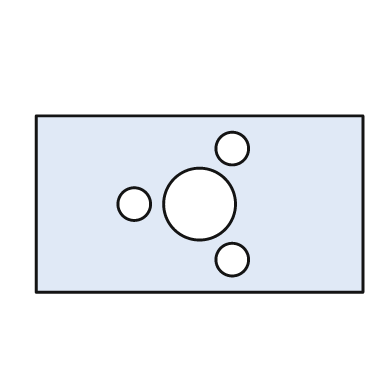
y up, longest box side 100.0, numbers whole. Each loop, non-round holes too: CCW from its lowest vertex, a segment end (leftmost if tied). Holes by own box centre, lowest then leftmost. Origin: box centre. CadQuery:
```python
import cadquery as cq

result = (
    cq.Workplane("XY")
    .moveTo(-50.0, -27.0)
    .lineTo(50.0, -27.0)
    .lineTo(50.0, 27.0)
    .lineTo(-50.0, 27.0)
    .close()
    .moveTo(10.0, -17.0)
    .circle(5.0)
    .moveTo(-20.0, 0.0)
    .circle(5.0)
    .moveTo(0.0, 0.0)
    .circle(11.0)
    .moveTo(10.0, 17.0)
    .circle(5.0)
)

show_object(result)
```